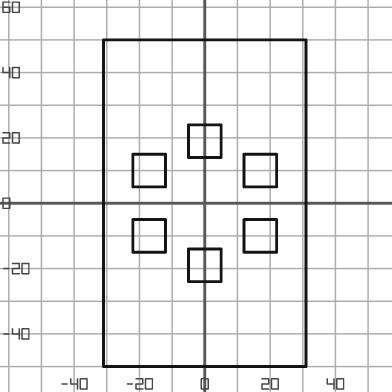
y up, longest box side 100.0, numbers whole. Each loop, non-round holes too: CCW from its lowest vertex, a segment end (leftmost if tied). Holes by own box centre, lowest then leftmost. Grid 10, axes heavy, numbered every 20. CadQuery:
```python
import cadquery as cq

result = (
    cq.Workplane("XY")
    .moveTo(-31.0, -50.0)
    .lineTo(31.0, -50.0)
    .lineTo(31.0, 50.0)
    .lineTo(-31.0, 50.0)
    .close()
    .moveTo(-5.0, -24.0)
    .lineTo(5.0, -24.0)
    .lineTo(5.0, -14.0)
    .lineTo(-5.0, -14.0)
    .close()
    .moveTo(-22.0, -15.0)
    .lineTo(-12.0, -15.0)
    .lineTo(-12.0, -5.0)
    .lineTo(-22.0, -5.0)
    .close()
    .moveTo(12.0, -15.0)
    .lineTo(22.0, -15.0)
    .lineTo(22.0, -5.0)
    .lineTo(12.0, -5.0)
    .close()
    .moveTo(-22.0, 5.0)
    .lineTo(-12.0, 5.0)
    .lineTo(-12.0, 15.0)
    .lineTo(-22.0, 15.0)
    .close()
    .moveTo(12.0, 5.0)
    .lineTo(22.0, 5.0)
    .lineTo(22.0, 15.0)
    .lineTo(12.0, 15.0)
    .close()
    .moveTo(-5.0, 14.0)
    .lineTo(5.0, 14.0)
    .lineTo(5.0, 24.0)
    .lineTo(-5.0, 24.0)
    .close()
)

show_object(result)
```